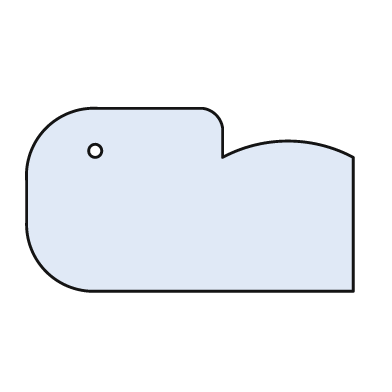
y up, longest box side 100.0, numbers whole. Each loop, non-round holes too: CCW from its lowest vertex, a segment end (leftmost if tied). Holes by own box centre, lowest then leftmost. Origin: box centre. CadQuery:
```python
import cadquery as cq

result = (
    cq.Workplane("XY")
    .moveTo(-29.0, -28.0)
    .lineTo(50.0, -28.0)
    .lineTo(50.0, 13.0)
    .threePointArc((30.0, 18.0), (10.0, 13.0))
    .lineTo(10.0, 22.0)
    .threePointArc((8.0, 26.0), (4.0, 28.0))
    .lineTo(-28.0, 28.0)
    .threePointArc((-44.0, 22.0), (-50.0, 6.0))
    .lineTo(-50.0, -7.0)
    .threePointArc((-44.0, -22.0), (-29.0, -28.0))
    .close()
    .moveTo(-29.0, 15.0)
    .circle(2.0)
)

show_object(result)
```